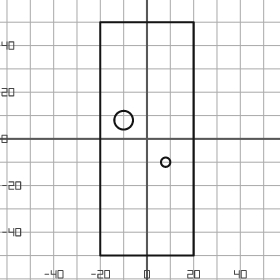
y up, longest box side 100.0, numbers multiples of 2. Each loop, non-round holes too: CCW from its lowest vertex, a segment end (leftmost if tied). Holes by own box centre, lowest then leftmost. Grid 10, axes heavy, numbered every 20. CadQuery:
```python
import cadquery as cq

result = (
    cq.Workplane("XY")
    .moveTo(-20.0, -50.0)
    .lineTo(20.0, -50.0)
    .lineTo(20.0, 50.0)
    .lineTo(-20.0, 50.0)
    .close()
    .moveTo(8.0, -10.0)
    .circle(2.0)
    .moveTo(-10.0, 8.0)
    .circle(4.0)
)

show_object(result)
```